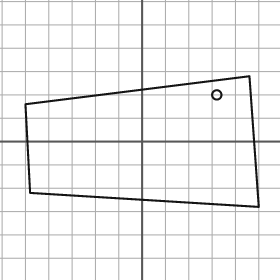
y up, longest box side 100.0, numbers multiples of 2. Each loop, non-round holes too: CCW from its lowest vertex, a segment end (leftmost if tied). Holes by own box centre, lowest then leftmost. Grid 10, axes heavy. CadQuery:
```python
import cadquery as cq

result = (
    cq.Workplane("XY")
    .moveTo(50.0, -28.0)
    .lineTo(46.0, 28.0)
    .lineTo(-50.0, 16.0)
    .lineTo(-48.0, -22.0)
    .close()
    .moveTo(32.0, 20.0)
    .circle(2.0)
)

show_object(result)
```